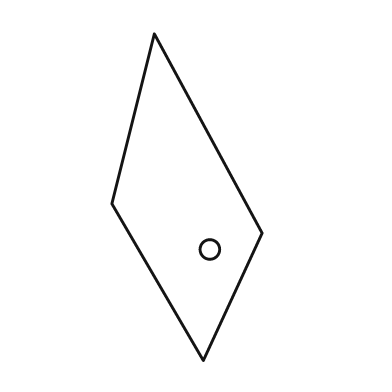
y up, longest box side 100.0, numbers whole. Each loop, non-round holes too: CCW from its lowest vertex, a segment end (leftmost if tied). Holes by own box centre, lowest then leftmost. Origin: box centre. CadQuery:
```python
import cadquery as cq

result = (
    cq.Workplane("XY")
    .moveTo(5.0, -50.0)
    .lineTo(23.0, -11.0)
    .lineTo(-10.0, 50.0)
    .lineTo(-23.0, -2.0)
    .close()
    .moveTo(7.0, -16.0)
    .circle(3.0)
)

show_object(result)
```